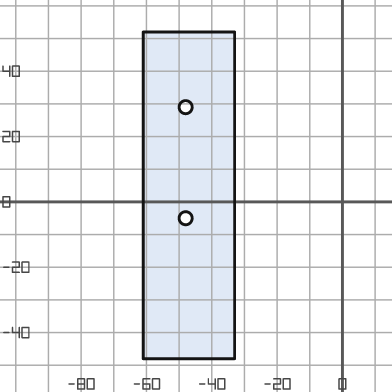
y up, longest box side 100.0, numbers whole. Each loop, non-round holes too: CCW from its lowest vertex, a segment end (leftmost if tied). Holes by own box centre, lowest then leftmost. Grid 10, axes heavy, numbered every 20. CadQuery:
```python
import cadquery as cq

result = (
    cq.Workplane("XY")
    .moveTo(-61.0, -48.0)
    .lineTo(-33.0, -48.0)
    .lineTo(-33.0, 52.0)
    .lineTo(-61.0, 52.0)
    .close()
    .moveTo(-48.0, -5.0)
    .circle(2.0)
    .moveTo(-48.0, 29.0)
    .circle(2.0)
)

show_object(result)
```